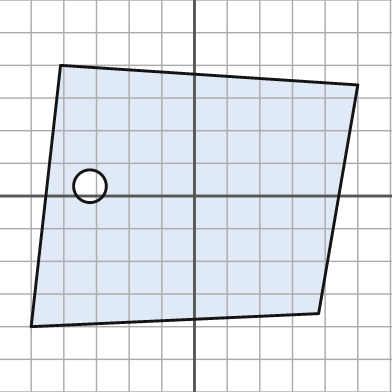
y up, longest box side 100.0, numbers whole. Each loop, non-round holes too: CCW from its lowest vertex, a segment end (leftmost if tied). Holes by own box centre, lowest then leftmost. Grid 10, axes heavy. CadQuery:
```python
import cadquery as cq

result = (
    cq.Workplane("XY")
    .moveTo(-50.0, -40.0)
    .lineTo(38.0, -36.0)
    .lineTo(50.0, 34.0)
    .lineTo(-41.0, 40.0)
    .close()
    .moveTo(-32.0, 3.0)
    .circle(5.0)
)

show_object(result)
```